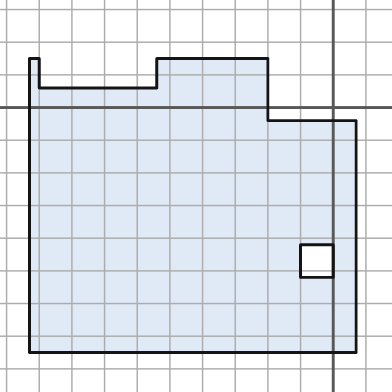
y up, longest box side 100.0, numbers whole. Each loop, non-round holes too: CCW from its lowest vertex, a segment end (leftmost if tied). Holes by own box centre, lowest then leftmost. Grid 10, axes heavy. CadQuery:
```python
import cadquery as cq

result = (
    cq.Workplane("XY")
    .moveTo(-93.0, -75.0)
    .lineTo(7.0, -75.0)
    .lineTo(7.0, -4.0)
    .lineTo(-20.0, -4.0)
    .lineTo(-20.0, 15.0)
    .lineTo(-54.0, 15.0)
    .lineTo(-54.0, 6.0)
    .lineTo(-90.0, 6.0)
    .lineTo(-90.0, 15.0)
    .lineTo(-93.0, 15.0)
    .close()
    .moveTo(-10.0, -52.0)
    .lineTo(0.0, -52.0)
    .lineTo(0.0, -42.0)
    .lineTo(-10.0, -42.0)
    .close()
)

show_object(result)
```